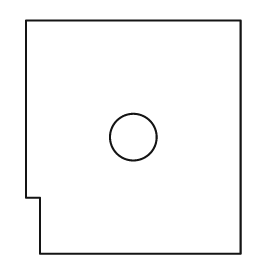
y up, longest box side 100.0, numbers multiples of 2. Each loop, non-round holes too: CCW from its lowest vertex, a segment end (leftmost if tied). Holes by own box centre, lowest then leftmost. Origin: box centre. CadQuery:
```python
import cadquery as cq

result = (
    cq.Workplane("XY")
    .moveTo(-40.0, -50.0)
    .lineTo(46.0, -50.0)
    .lineTo(46.0, 50.0)
    .lineTo(-46.0, 50.0)
    .lineTo(-46.0, -26.0)
    .lineTo(-40.0, -26.0)
    .close()
    .moveTo(0.0, 0.0)
    .circle(10.0)
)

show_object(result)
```